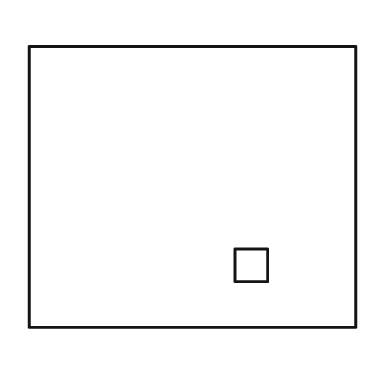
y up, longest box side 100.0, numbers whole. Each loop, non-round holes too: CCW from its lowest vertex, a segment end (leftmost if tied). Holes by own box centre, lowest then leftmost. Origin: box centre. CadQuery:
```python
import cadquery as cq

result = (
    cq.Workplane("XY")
    .moveTo(-50.0, -43.0)
    .lineTo(50.0, -43.0)
    .lineTo(50.0, 43.0)
    .lineTo(-50.0, 43.0)
    .close()
    .moveTo(13.0, -29.0)
    .lineTo(23.0, -29.0)
    .lineTo(23.0, -19.0)
    .lineTo(13.0, -19.0)
    .close()
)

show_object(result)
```